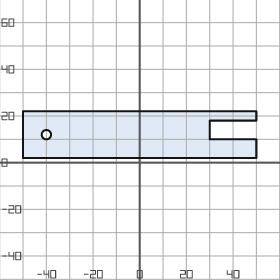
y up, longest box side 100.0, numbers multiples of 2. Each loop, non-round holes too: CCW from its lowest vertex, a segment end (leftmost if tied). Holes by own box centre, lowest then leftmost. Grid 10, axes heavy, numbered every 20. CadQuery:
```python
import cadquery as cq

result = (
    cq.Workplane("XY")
    .moveTo(-50.0, 2.0)
    .lineTo(50.0, 2.0)
    .lineTo(50.0, 10.0)
    .lineTo(30.0, 10.0)
    .lineTo(30.0, 18.0)
    .lineTo(50.0, 18.0)
    .lineTo(50.0, 22.0)
    .lineTo(-50.0, 22.0)
    .close()
    .moveTo(-40.0, 12.0)
    .circle(2.0)
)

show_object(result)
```